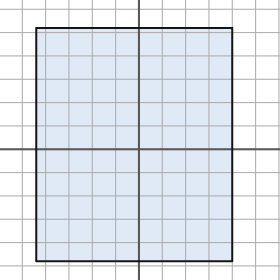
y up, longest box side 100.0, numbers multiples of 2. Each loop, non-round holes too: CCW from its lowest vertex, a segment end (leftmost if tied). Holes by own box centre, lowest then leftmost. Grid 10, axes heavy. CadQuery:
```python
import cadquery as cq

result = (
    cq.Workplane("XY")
    .moveTo(-44.0, -48.0)
    .lineTo(40.0, -48.0)
    .lineTo(40.0, 52.0)
    .lineTo(-44.0, 52.0)
    .close()
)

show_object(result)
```